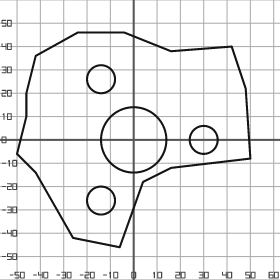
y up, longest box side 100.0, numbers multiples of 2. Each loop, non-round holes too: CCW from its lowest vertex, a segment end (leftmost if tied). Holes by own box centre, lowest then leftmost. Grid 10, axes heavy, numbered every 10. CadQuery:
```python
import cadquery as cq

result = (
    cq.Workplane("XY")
    .moveTo(-6.0, -46.0)
    .lineTo(4.0, -18.0)
    .lineTo(16.0, -12.0)
    .lineTo(50.0, -8.0)
    .lineTo(48.0, 22.0)
    .lineTo(42.0, 40.0)
    .lineTo(16.0, 38.0)
    .lineTo(-4.0, 46.0)
    .lineTo(-24.0, 46.0)
    .lineTo(-42.0, 36.0)
    .lineTo(-46.0, 20.0)
    .lineTo(-46.0, 10.0)
    .lineTo(-50.0, -6.0)
    .lineTo(-42.0, -14.0)
    .lineTo(-26.0, -42.0)
    .close()
    .moveTo(-14.0, -26.0)
    .circle(6.0)
    .moveTo(0.0, 0.0)
    .circle(14.0)
    .moveTo(30.0, 0.0)
    .circle(6.0)
    .moveTo(-14.0, 26.0)
    .circle(6.0)
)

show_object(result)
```